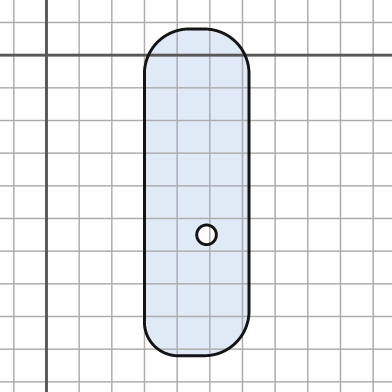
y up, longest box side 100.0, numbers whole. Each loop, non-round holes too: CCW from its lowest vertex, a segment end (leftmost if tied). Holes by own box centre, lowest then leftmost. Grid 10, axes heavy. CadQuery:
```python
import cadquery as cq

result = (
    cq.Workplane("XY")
    .moveTo(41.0, -92.0)
    .lineTo(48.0, -92.0)
    .threePointArc((58.0, -88.0), (62.0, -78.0))
    .lineTo(62.0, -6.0)
    .threePointArc((58.0, 4.0), (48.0, 8.0))
    .lineTo(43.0, 8.0)
    .threePointArc((34.0, 4.0), (30.0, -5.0))
    .lineTo(30.0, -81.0)
    .threePointArc((33.0, -89.0), (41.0, -92.0))
    .close()
    .moveTo(49.0, -55.0)
    .circle(3.0)
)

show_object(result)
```